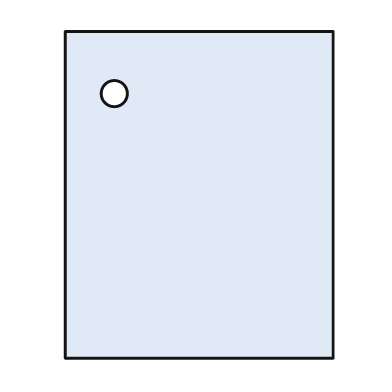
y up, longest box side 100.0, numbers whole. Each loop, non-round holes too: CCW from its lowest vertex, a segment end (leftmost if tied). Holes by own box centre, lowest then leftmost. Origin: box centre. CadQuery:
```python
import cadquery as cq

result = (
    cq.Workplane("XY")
    .moveTo(-41.0, -50.0)
    .lineTo(41.0, -50.0)
    .lineTo(41.0, 50.0)
    .lineTo(-41.0, 50.0)
    .close()
    .moveTo(-26.0, 31.0)
    .circle(4.0)
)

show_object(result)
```